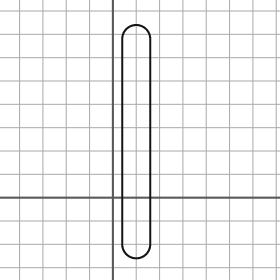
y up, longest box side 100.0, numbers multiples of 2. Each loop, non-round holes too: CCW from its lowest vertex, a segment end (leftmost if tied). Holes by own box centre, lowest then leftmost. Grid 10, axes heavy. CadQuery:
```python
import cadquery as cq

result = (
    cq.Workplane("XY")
    .moveTo(4.0, -20.0)
    .threePointArc((10.0, -26.0), (16.0, -20.0))
    .lineTo(16.0, 68.0)
    .threePointArc((10.0, 74.0), (4.0, 68.0))
    .close()
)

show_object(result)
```